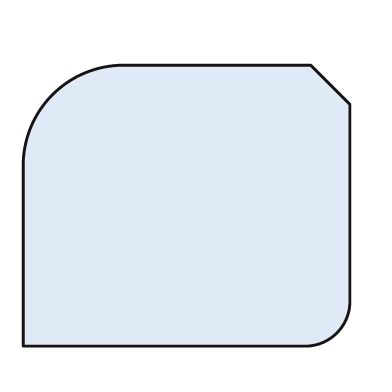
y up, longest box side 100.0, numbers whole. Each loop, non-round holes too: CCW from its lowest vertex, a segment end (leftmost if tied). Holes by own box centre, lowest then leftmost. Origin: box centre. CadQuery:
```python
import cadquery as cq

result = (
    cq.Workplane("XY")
    .moveTo(-50.0, -43.0)
    .lineTo(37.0, -43.0)
    .threePointArc((46.0, -39.0), (50.0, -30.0))
    .lineTo(50.0, 31.0)
    .lineTo(38.0, 43.0)
    .lineTo(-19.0, 43.0)
    .threePointArc((-41.0, 34.0), (-50.0, 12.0))
    .close()
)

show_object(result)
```